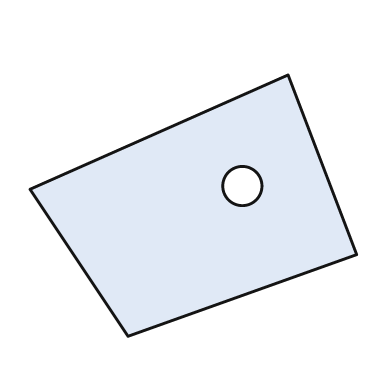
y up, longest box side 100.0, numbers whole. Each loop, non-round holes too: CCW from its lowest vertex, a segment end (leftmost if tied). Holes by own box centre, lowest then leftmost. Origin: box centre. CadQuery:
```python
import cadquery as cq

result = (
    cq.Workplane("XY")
    .moveTo(-20.0, -40.0)
    .lineTo(50.0, -15.0)
    .lineTo(29.0, 40.0)
    .lineTo(-50.0, 5.0)
    .close()
    .moveTo(15.0, 6.0)
    .circle(6.0)
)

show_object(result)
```